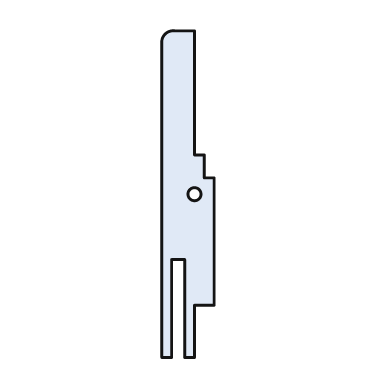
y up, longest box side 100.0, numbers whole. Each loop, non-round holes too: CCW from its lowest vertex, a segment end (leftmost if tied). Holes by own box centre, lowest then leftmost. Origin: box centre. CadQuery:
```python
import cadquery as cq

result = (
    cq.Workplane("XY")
    .moveTo(-8.0, -50.0)
    .lineTo(-5.0, -50.0)
    .lineTo(-5.0, -20.0)
    .lineTo(-1.0, -20.0)
    .lineTo(-1.0, -50.0)
    .lineTo(2.0, -50.0)
    .lineTo(2.0, -34.0)
    .lineTo(8.0, -34.0)
    .lineTo(8.0, 5.0)
    .lineTo(5.0, 5.0)
    .lineTo(5.0, 12.0)
    .lineTo(2.0, 12.0)
    .lineTo(2.0, 50.0)
    .lineTo(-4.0, 50.0)
    .threePointArc((-7.0, 49.0), (-8.0, 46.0))
    .close()
    .moveTo(2.0, 0.0)
    .circle(2.0)
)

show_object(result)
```